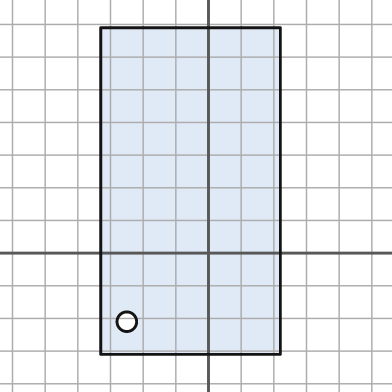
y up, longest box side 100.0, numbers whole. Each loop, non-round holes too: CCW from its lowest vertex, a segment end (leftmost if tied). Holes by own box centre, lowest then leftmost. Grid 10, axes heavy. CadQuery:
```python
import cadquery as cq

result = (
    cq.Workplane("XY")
    .moveTo(-33.0, -31.0)
    .lineTo(22.0, -31.0)
    .lineTo(22.0, 69.0)
    .lineTo(-33.0, 69.0)
    .close()
    .moveTo(-25.0, -21.0)
    .circle(3.0)
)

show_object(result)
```